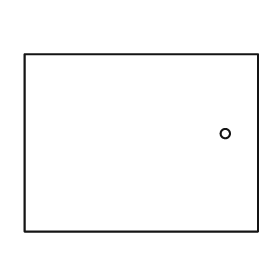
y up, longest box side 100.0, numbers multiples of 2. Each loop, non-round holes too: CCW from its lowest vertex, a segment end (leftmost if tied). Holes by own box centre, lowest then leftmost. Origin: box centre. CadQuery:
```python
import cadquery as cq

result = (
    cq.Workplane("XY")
    .moveTo(-50.0, -38.0)
    .lineTo(50.0, -38.0)
    .lineTo(50.0, 38.0)
    .lineTo(-50.0, 38.0)
    .close()
    .moveTo(36.0, 4.0)
    .circle(2.0)
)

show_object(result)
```